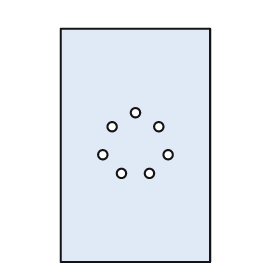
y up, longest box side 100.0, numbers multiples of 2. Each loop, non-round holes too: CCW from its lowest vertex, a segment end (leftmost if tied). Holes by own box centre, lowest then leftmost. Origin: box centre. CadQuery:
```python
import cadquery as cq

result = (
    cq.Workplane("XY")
    .moveTo(-32.0, -50.0)
    .lineTo(32.0, -50.0)
    .lineTo(32.0, 50.0)
    .lineTo(-32.0, 50.0)
    .close()
    .moveTo(-6.0, -12.0)
    .circle(2.0)
    .moveTo(6.0, -12.0)
    .circle(2.0)
    .moveTo(-14.0, -4.0)
    .circle(2.0)
    .moveTo(14.0, -4.0)
    .circle(2.0)
    .moveTo(-10.0, 8.0)
    .circle(2.0)
    .moveTo(10.0, 8.0)
    .circle(2.0)
    .moveTo(0.0, 14.0)
    .circle(2.0)
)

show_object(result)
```